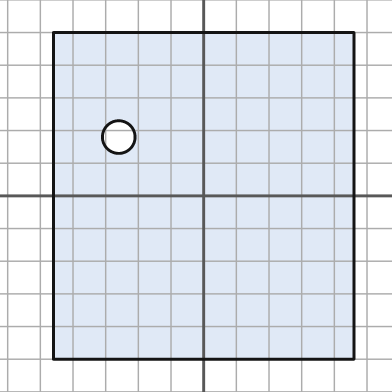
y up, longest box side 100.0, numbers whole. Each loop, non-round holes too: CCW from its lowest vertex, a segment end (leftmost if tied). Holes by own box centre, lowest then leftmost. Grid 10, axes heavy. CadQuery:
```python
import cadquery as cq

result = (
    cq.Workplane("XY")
    .moveTo(-46.0, -50.0)
    .lineTo(46.0, -50.0)
    .lineTo(46.0, 50.0)
    .lineTo(-46.0, 50.0)
    .close()
    .moveTo(-26.0, 18.0)
    .circle(5.0)
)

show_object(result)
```